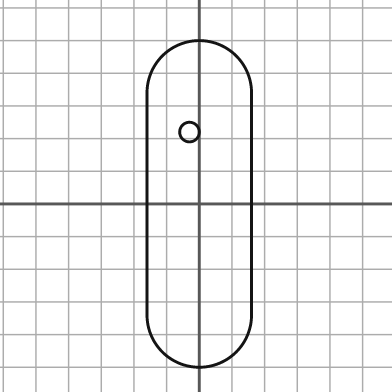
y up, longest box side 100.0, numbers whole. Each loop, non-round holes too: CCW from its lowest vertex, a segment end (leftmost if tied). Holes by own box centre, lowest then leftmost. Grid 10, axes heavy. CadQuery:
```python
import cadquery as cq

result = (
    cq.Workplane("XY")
    .moveTo(-16.0, -34.0)
    .threePointArc((0.0, -50.0), (16.0, -34.0))
    .lineTo(16.0, 34.0)
    .threePointArc((0.0, 50.0), (-16.0, 34.0))
    .close()
    .moveTo(-3.0, 22.0)
    .circle(3.0)
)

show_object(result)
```